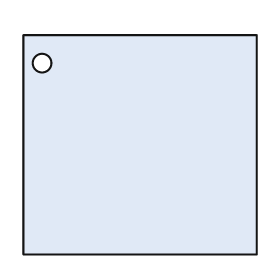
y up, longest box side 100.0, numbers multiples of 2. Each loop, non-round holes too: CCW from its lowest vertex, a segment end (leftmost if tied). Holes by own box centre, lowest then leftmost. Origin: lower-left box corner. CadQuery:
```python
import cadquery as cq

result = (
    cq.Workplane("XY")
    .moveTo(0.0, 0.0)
    .lineTo(100.0, 0.0)
    .lineTo(100.0, 94.0)
    .lineTo(0.0, 94.0)
    .close()
    .moveTo(8.0, 82.0)
    .circle(4.0)
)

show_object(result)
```